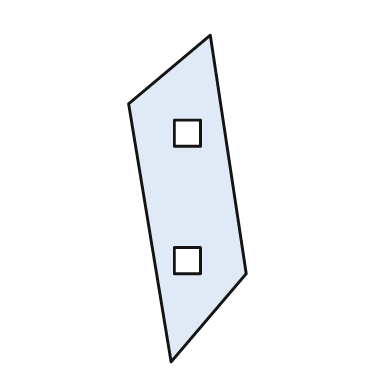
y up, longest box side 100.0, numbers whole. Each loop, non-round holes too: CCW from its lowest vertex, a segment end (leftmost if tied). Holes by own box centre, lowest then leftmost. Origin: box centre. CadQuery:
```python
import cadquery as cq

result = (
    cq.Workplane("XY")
    .moveTo(-5.0, -50.0)
    .lineTo(18.0, -23.0)
    .lineTo(7.0, 50.0)
    .lineTo(-18.0, 29.0)
    .close()
    .moveTo(-4.0, -23.0)
    .lineTo(4.0, -23.0)
    .lineTo(4.0, -15.0)
    .lineTo(-4.0, -15.0)
    .close()
    .moveTo(-4.0, 16.0)
    .lineTo(4.0, 16.0)
    .lineTo(4.0, 24.0)
    .lineTo(-4.0, 24.0)
    .close()
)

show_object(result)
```